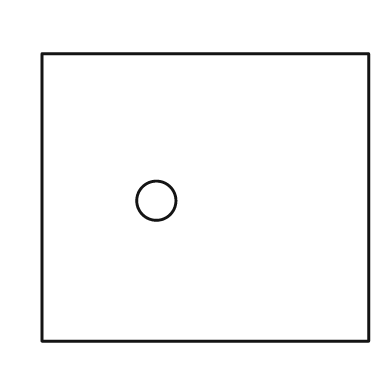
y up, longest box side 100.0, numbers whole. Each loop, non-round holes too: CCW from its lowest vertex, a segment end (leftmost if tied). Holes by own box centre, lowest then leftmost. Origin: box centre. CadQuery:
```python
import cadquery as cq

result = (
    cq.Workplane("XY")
    .moveTo(-50.0, -44.0)
    .lineTo(50.0, -44.0)
    .lineTo(50.0, 44.0)
    .lineTo(-50.0, 44.0)
    .close()
    .moveTo(-15.0, -1.0)
    .circle(6.0)
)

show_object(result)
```